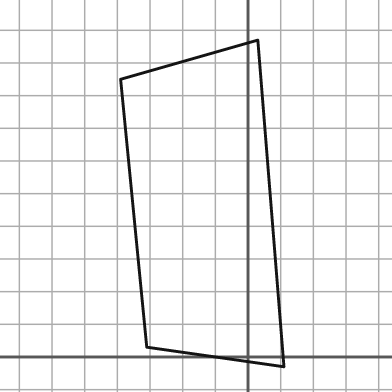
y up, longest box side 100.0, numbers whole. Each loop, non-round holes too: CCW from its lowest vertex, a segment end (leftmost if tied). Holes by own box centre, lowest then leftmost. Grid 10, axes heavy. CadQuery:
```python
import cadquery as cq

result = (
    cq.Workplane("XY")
    .moveTo(11.0, -3.0)
    .lineTo(3.0, 97.0)
    .lineTo(-39.0, 85.0)
    .lineTo(-31.0, 3.0)
    .close()
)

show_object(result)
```